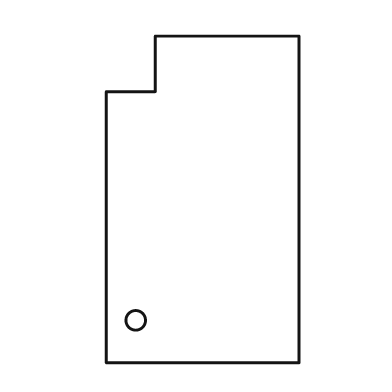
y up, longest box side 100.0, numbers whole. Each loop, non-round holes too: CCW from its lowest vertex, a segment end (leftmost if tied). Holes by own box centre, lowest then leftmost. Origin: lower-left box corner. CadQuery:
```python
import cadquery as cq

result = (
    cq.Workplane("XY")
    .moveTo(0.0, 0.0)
    .lineTo(59.0, 0.0)
    .lineTo(59.0, 100.0)
    .lineTo(15.0, 100.0)
    .lineTo(15.0, 83.0)
    .lineTo(0.0, 83.0)
    .close()
    .moveTo(9.0, 13.0)
    .circle(3.0)
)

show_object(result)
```